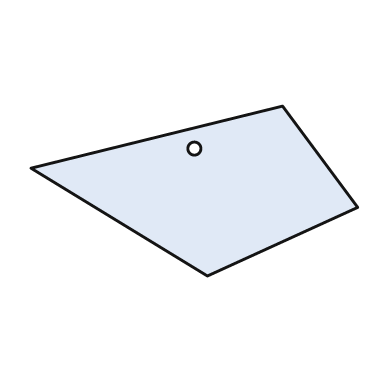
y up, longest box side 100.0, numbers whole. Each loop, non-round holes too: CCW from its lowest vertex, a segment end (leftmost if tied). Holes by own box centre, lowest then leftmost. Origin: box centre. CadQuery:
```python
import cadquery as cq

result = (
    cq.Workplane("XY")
    .moveTo(4.0, -26.0)
    .lineTo(50.0, -5.0)
    .lineTo(27.0, 26.0)
    .lineTo(-50.0, 7.0)
    .close()
    .moveTo(0.0, 13.0)
    .circle(2.0)
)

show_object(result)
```